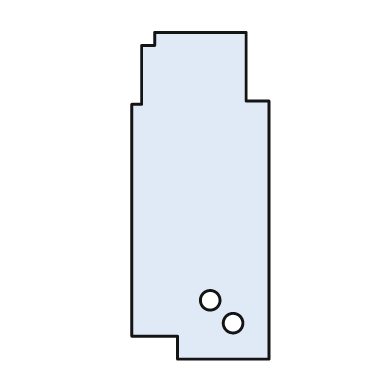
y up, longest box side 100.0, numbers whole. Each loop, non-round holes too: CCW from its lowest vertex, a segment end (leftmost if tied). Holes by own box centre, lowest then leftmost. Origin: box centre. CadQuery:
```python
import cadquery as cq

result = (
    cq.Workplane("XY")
    .moveTo(-7.0, -50.0)
    .lineTo(21.0, -50.0)
    .lineTo(21.0, 29.0)
    .lineTo(14.0, 29.0)
    .lineTo(14.0, 50.0)
    .lineTo(-14.0, 50.0)
    .lineTo(-14.0, 46.0)
    .lineTo(-18.0, 46.0)
    .lineTo(-18.0, 28.0)
    .lineTo(-21.0, 28.0)
    .lineTo(-21.0, -43.0)
    .lineTo(-7.0, -43.0)
    .close()
    .moveTo(10.0, -39.0)
    .circle(3.0)
    .moveTo(3.0, -32.0)
    .circle(3.0)
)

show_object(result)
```